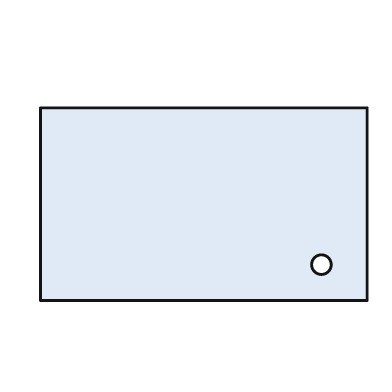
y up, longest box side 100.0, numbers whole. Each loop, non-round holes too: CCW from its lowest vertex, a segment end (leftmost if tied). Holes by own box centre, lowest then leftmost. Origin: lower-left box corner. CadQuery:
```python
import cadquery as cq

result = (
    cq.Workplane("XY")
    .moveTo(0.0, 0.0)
    .lineTo(100.0, 0.0)
    .lineTo(100.0, 59.0)
    .lineTo(0.0, 59.0)
    .close()
    .moveTo(86.0, 11.0)
    .circle(3.0)
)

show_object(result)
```